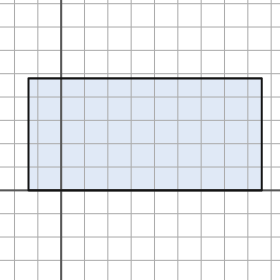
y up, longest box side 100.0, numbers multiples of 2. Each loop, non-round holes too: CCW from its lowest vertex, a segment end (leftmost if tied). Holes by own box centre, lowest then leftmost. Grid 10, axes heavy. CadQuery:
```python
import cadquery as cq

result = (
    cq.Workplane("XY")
    .moveTo(-14.0, 0.0)
    .lineTo(86.0, 0.0)
    .lineTo(86.0, 48.0)
    .lineTo(-14.0, 48.0)
    .close()
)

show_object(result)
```